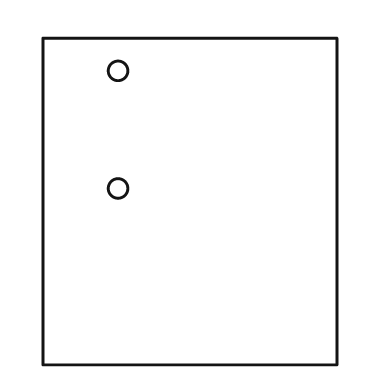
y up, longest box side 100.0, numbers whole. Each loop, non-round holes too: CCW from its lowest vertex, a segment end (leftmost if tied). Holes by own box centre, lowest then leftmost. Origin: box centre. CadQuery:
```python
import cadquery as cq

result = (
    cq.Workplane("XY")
    .moveTo(-45.0, -50.0)
    .lineTo(45.0, -50.0)
    .lineTo(45.0, 50.0)
    .lineTo(-45.0, 50.0)
    .close()
    .moveTo(-22.0, 4.0)
    .circle(3.0)
    .moveTo(-22.0, 40.0)
    .circle(3.0)
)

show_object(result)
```